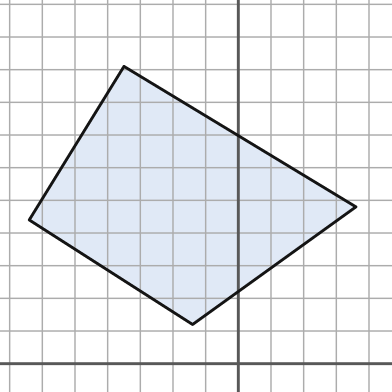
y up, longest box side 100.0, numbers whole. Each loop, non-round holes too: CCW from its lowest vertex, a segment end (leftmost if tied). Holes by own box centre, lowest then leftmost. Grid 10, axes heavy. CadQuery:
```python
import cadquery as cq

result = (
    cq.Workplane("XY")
    .moveTo(-14.0, 12.0)
    .lineTo(36.0, 48.0)
    .lineTo(-35.0, 91.0)
    .lineTo(-64.0, 44.0)
    .close()
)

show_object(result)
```